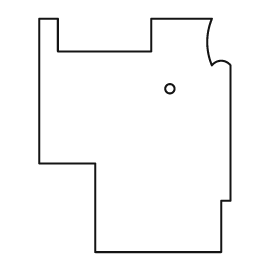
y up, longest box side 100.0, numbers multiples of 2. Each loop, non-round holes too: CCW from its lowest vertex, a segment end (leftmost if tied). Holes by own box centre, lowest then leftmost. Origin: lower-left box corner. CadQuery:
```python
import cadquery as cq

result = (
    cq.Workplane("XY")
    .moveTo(24.0, 0.0)
    .lineTo(78.0, 0.0)
    .lineTo(78.0, 22.0)
    .lineTo(82.0, 22.0)
    .lineTo(82.0, 80.0)
    .threePointArc((78.0, 82.0), (74.0, 80.0))
    .threePointArc((72.0, 90.0), (74.0, 100.0))
    .lineTo(48.0, 100.0)
    .lineTo(48.0, 86.0)
    .lineTo(8.0, 86.0)
    .lineTo(8.0, 100.0)
    .lineTo(0.0, 100.0)
    .lineTo(0.0, 38.0)
    .lineTo(24.0, 38.0)
    .close()
    .moveTo(56.0, 70.0)
    .circle(2.0)
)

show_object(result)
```